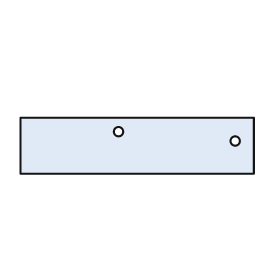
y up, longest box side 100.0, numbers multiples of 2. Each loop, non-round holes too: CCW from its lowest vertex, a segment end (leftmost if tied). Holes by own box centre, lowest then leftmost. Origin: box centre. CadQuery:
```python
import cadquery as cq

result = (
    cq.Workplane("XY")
    .moveTo(-50.0, -12.0)
    .lineTo(50.0, -12.0)
    .lineTo(50.0, 12.0)
    .lineTo(-50.0, 12.0)
    .close()
    .moveTo(42.0, 2.0)
    .circle(2.0)
    .moveTo(-8.0, 6.0)
    .circle(2.0)
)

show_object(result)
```